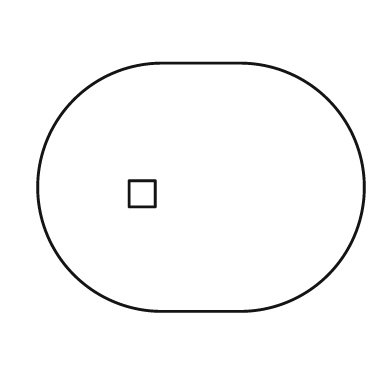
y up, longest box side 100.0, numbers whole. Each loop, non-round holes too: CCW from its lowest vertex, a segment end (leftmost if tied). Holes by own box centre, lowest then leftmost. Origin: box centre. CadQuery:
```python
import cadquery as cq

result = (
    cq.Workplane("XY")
    .moveTo(-12.0, -38.0)
    .lineTo(12.0, -38.0)
    .threePointArc((50.0, 0.0), (12.0, 38.0))
    .lineTo(-12.0, 38.0)
    .threePointArc((-50.0, 0.0), (-12.0, -38.0))
    .close()
    .moveTo(-22.0, -6.0)
    .lineTo(-14.0, -6.0)
    .lineTo(-14.0, 2.0)
    .lineTo(-22.0, 2.0)
    .close()
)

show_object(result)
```